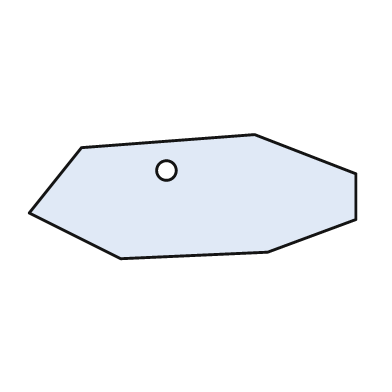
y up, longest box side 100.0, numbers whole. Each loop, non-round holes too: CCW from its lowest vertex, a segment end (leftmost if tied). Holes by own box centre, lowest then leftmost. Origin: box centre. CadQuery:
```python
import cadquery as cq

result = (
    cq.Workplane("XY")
    .moveTo(-22.0, -19.0)
    .lineTo(23.0, -17.0)
    .lineTo(50.0, -7.0)
    .lineTo(50.0, 7.0)
    .lineTo(19.0, 19.0)
    .lineTo(-34.0, 15.0)
    .lineTo(-50.0, -5.0)
    .close()
    .moveTo(-8.0, 8.0)
    .circle(3.0)
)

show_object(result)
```